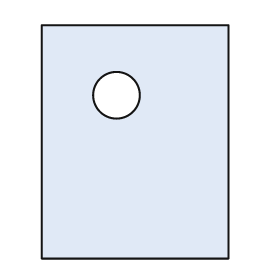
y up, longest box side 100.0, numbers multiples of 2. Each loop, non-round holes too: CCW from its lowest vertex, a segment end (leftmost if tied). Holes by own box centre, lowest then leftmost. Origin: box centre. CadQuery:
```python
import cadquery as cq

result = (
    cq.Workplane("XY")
    .moveTo(-40.0, -50.0)
    .lineTo(40.0, -50.0)
    .lineTo(40.0, 50.0)
    .lineTo(-40.0, 50.0)
    .close()
    .moveTo(-8.0, 20.0)
    .circle(10.0)
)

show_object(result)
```